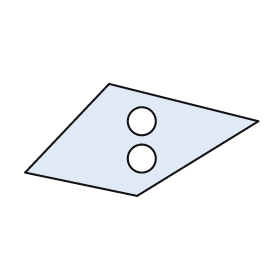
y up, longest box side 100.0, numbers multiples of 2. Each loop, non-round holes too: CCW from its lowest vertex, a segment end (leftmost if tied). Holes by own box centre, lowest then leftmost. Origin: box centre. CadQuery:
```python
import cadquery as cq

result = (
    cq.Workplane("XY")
    .moveTo(-2.0, -24.0)
    .lineTo(50.0, 8.0)
    .lineTo(-14.0, 24.0)
    .lineTo(-50.0, -14.0)
    .close()
    .moveTo(0.0, -8.0)
    .circle(6.0)
    .moveTo(0.0, 8.0)
    .circle(6.0)
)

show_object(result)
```